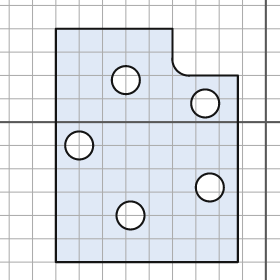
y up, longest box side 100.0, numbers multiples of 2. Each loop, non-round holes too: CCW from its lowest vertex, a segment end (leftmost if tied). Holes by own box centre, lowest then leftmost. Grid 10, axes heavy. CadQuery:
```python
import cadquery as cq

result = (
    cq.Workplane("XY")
    .moveTo(-90.0, -60.0)
    .lineTo(-12.0, -60.0)
    .lineTo(-12.0, 20.0)
    .lineTo(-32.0, 20.0)
    .threePointArc((-38.0, 22.0), (-40.0, 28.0))
    .lineTo(-40.0, 40.0)
    .lineTo(-90.0, 40.0)
    .close()
    .moveTo(-58.0, -40.0)
    .circle(6.0)
    .moveTo(-24.0, -28.0)
    .circle(6.0)
    .moveTo(-80.0, -10.0)
    .circle(6.0)
    .moveTo(-26.0, 8.0)
    .circle(6.0)
    .moveTo(-60.0, 18.0)
    .circle(6.0)
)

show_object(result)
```